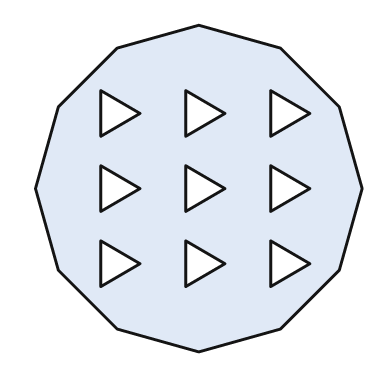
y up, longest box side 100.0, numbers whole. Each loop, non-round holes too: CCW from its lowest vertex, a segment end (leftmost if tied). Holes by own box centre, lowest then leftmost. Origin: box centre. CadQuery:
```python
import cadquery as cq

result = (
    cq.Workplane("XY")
    .moveTo(0.0, -50.0)
    .lineTo(25.0, -43.0)
    .lineTo(43.0, -25.0)
    .lineTo(50.0, 0.0)
    .lineTo(43.0, 25.0)
    .lineTo(25.0, 43.0)
    .lineTo(0.0, 50.0)
    .lineTo(-25.0, 43.0)
    .lineTo(-43.0, 25.0)
    .lineTo(-50.0, 0.0)
    .lineTo(-43.0, -25.0)
    .lineTo(-25.0, -43.0)
    .close()
    .moveTo(-30.0, -30.0)
    .lineTo(-18.0, -23.0)
    .lineTo(-30.0, -16.0)
    .close()
    .moveTo(-4.0, -30.0)
    .lineTo(8.0, -23.0)
    .lineTo(-4.0, -16.0)
    .close()
    .moveTo(22.0, -30.0)
    .lineTo(34.0, -23.0)
    .lineTo(22.0, -16.0)
    .close()
    .moveTo(-30.0, -7.0)
    .lineTo(-18.0, 0.0)
    .lineTo(-30.0, 7.0)
    .close()
    .moveTo(-4.0, -7.0)
    .lineTo(8.0, 0.0)
    .lineTo(-4.0, 7.0)
    .close()
    .moveTo(22.0, -7.0)
    .lineTo(34.0, 0.0)
    .lineTo(22.0, 7.0)
    .close()
    .moveTo(-30.0, 16.0)
    .lineTo(-18.0, 23.0)
    .lineTo(-30.0, 30.0)
    .close()
    .moveTo(-4.0, 16.0)
    .lineTo(8.0, 23.0)
    .lineTo(-4.0, 30.0)
    .close()
    .moveTo(22.0, 16.0)
    .lineTo(34.0, 23.0)
    .lineTo(22.0, 30.0)
    .close()
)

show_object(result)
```